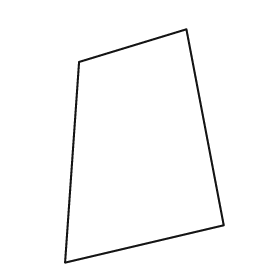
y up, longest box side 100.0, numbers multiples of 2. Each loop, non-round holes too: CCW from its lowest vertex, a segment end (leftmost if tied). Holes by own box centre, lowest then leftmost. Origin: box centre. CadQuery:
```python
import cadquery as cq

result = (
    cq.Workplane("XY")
    .moveTo(-34.0, -50.0)
    .lineTo(34.0, -34.0)
    .lineTo(18.0, 50.0)
    .lineTo(-28.0, 36.0)
    .close()
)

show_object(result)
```